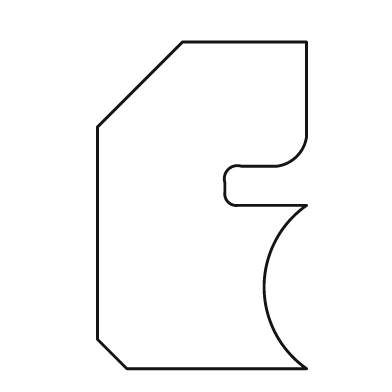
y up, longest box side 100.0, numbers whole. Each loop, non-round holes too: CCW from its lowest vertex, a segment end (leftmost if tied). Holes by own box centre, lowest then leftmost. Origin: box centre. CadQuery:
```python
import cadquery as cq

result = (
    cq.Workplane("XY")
    .moveTo(-23.0, -50.0)
    .lineTo(32.0, -50.0)
    .threePointArc((19.0, -25.0), (32.0, 0.0))
    .lineTo(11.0, 0.0)
    .threePointArc((8.0, 1.0), (7.0, 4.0))
    .lineTo(7.0, 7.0)
    .threePointArc((8.0, 11.0), (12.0, 12.0))
    .lineTo(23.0, 12.0)
    .threePointArc((29.0, 15.0), (32.0, 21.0))
    .lineTo(32.0, 50.0)
    .lineTo(-6.0, 50.0)
    .lineTo(-32.0, 24.0)
    .lineTo(-32.0, -41.0)
    .close()
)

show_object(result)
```